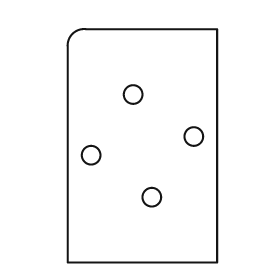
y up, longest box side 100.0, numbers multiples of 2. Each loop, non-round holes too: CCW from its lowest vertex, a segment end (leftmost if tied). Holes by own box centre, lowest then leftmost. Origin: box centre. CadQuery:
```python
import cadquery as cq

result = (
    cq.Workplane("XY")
    .moveTo(-32.0, -50.0)
    .lineTo(32.0, -50.0)
    .lineTo(32.0, 50.0)
    .lineTo(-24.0, 50.0)
    .threePointArc((-30.0, 48.0), (-32.0, 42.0))
    .close()
    .moveTo(4.0, -22.0)
    .circle(4.0)
    .moveTo(-22.0, -4.0)
    .circle(4.0)
    .moveTo(22.0, 4.0)
    .circle(4.0)
    .moveTo(-4.0, 22.0)
    .circle(4.0)
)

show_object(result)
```